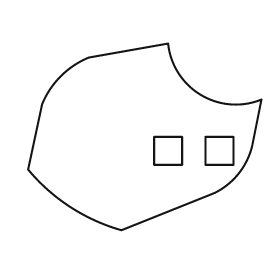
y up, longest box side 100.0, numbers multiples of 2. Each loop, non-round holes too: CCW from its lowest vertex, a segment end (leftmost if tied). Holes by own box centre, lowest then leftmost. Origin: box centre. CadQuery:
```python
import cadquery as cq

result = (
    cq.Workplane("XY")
    .moveTo(-10.0, -40.0)
    .lineTo(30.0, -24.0)
    .threePointArc((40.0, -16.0), (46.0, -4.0))
    .lineTo(50.0, 16.0)
    .threePointArc((24.0, 18.0), (10.0, 40.0))
    .lineTo(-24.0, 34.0)
    .threePointArc((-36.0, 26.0), (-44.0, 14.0))
    .lineTo(-50.0, -14.0)
    .threePointArc((-32.0, -30.0), (-10.0, -40.0))
    .close()
    .moveTo(4.0, -12.0)
    .lineTo(16.0, -12.0)
    .lineTo(16.0, 0.0)
    .lineTo(4.0, 0.0)
    .close()
    .moveTo(26.0, -12.0)
    .lineTo(38.0, -12.0)
    .lineTo(38.0, 0.0)
    .lineTo(26.0, 0.0)
    .close()
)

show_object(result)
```